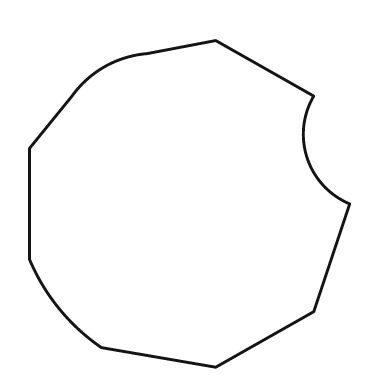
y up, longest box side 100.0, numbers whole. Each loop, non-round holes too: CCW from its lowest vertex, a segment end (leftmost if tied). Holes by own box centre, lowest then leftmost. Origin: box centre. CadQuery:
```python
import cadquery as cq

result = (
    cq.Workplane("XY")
    .moveTo(8.0, -50.0)
    .lineTo(38.0, -33.0)
    .lineTo(49.0, 0.0)
    .threePointArc((36.0, 14.0), (38.0, 33.0))
    .lineTo(8.0, 50.0)
    .lineTo(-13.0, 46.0)
    .threePointArc((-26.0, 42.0), (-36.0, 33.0))
    .lineTo(-49.0, 17.0)
    .lineTo(-49.0, -17.0)
    .threePointArc((-40.0, -32.0), (-27.0, -44.0))
    .close()
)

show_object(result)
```